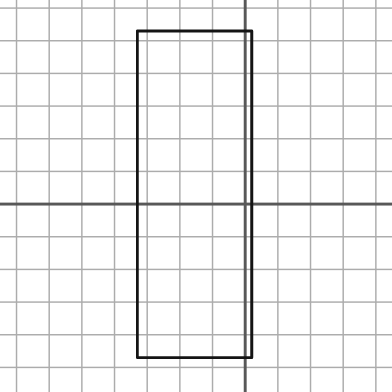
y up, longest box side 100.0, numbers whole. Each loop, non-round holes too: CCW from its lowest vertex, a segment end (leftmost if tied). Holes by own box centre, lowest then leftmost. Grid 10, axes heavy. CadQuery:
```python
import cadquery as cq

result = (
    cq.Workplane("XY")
    .moveTo(-33.0, -47.0)
    .lineTo(2.0, -47.0)
    .lineTo(2.0, 53.0)
    .lineTo(-33.0, 53.0)
    .close()
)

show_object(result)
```